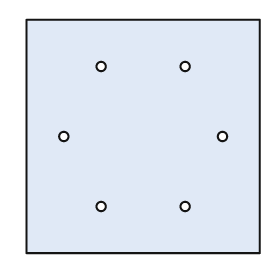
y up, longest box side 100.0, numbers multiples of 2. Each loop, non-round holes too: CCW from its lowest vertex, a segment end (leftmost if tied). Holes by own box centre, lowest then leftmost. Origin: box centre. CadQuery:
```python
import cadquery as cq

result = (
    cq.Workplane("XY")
    .moveTo(-50.0, -50.0)
    .lineTo(50.0, -50.0)
    .lineTo(50.0, 50.0)
    .lineTo(-50.0, 50.0)
    .close()
    .moveTo(-18.0, -30.0)
    .circle(2.0)
    .moveTo(18.0, -30.0)
    .circle(2.0)
    .moveTo(-34.0, 0.0)
    .circle(2.0)
    .moveTo(34.0, 0.0)
    .circle(2.0)
    .moveTo(-18.0, 30.0)
    .circle(2.0)
    .moveTo(18.0, 30.0)
    .circle(2.0)
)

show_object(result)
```